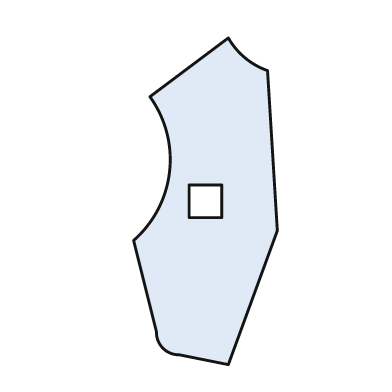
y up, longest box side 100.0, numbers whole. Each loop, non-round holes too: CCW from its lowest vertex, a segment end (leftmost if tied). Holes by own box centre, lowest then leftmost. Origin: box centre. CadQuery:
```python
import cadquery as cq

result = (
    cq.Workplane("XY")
    .moveTo(7.0, -50.0)
    .lineTo(22.0, -9.0)
    .lineTo(19.0, 40.0)
    .threePointArc((12.0, 44.0), (7.0, 50.0))
    .lineTo(-17.0, 32.0)
    .threePointArc((-11.0, 9.0), (-22.0, -12.0))
    .lineTo(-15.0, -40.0)
    .threePointArc((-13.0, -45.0), (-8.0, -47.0))
    .close()
    .moveTo(-5.0, -5.0)
    .lineTo(5.0, -5.0)
    .lineTo(5.0, 5.0)
    .lineTo(-5.0, 5.0)
    .close()
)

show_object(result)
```